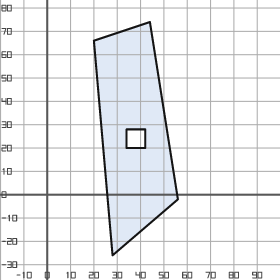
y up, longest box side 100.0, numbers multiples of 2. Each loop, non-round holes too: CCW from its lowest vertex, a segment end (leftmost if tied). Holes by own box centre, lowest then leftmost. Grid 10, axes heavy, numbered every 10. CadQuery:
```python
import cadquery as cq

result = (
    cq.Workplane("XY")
    .moveTo(28.0, -26.0)
    .lineTo(56.0, -2.0)
    .lineTo(44.0, 74.0)
    .lineTo(20.0, 66.0)
    .close()
    .moveTo(34.0, 20.0)
    .lineTo(42.0, 20.0)
    .lineTo(42.0, 28.0)
    .lineTo(34.0, 28.0)
    .close()
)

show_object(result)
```